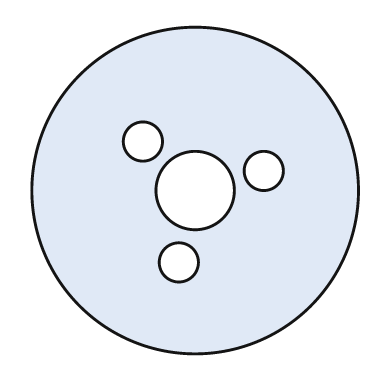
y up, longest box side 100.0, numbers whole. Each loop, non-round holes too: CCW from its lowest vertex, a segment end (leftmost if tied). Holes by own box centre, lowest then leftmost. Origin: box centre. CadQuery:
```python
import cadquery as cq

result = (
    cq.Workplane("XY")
    .moveTo(0.0, 0.0)
    .circle(50.0)
    .moveTo(-5.0, -22.0)
    .circle(6.0)
    .moveTo(0.0, 0.0)
    .circle(12.0)
    .moveTo(21.0, 6.0)
    .circle(6.0)
    .moveTo(-16.0, 15.0)
    .circle(6.0)
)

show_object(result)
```